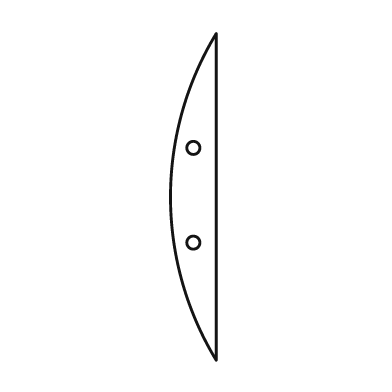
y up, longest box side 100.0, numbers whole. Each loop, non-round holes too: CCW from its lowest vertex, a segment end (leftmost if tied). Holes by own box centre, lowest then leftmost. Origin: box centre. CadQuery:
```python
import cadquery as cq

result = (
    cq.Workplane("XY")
    .moveTo(7.0, -50.0)
    .lineTo(7.0, 50.0)
    .threePointArc((-7.0, 0.0), (7.0, -50.0))
    .close()
    .moveTo(0.0, -14.0)
    .circle(2.0)
    .moveTo(0.0, 15.0)
    .circle(2.0)
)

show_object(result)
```